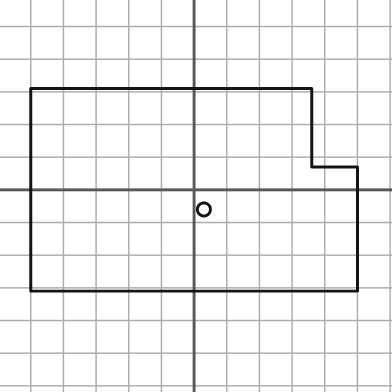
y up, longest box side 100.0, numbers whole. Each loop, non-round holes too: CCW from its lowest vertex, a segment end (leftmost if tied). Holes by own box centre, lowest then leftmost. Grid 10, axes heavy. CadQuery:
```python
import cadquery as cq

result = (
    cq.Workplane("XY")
    .moveTo(-50.0, -31.0)
    .lineTo(50.0, -31.0)
    .lineTo(50.0, 7.0)
    .lineTo(36.0, 7.0)
    .lineTo(36.0, 31.0)
    .lineTo(-50.0, 31.0)
    .close()
    .moveTo(3.0, -6.0)
    .circle(2.0)
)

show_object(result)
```